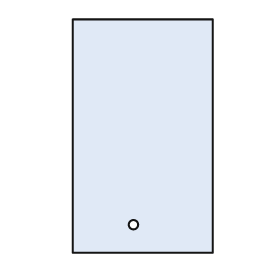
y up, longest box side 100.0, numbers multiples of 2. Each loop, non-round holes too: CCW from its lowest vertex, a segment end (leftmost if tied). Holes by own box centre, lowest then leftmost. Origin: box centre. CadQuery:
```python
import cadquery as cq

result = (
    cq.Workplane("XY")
    .moveTo(-30.0, -50.0)
    .lineTo(30.0, -50.0)
    .lineTo(30.0, 50.0)
    .lineTo(-30.0, 50.0)
    .close()
    .moveTo(-4.0, -38.0)
    .circle(2.0)
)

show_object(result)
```